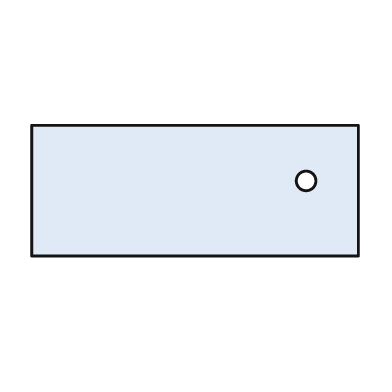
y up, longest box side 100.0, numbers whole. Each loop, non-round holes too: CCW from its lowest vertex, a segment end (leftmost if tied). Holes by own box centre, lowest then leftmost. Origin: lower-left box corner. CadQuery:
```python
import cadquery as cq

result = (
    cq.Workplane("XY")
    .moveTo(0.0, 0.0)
    .lineTo(100.0, 0.0)
    .lineTo(100.0, 40.0)
    .lineTo(0.0, 40.0)
    .close()
    .moveTo(84.0, 23.0)
    .circle(3.0)
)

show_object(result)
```